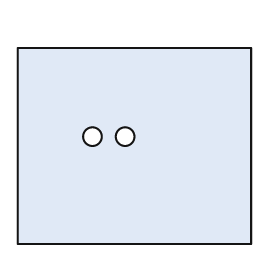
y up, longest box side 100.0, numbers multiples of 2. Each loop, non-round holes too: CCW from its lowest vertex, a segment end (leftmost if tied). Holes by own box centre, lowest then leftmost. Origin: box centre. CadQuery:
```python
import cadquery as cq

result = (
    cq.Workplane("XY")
    .moveTo(-50.0, -42.0)
    .lineTo(50.0, -42.0)
    .lineTo(50.0, 42.0)
    .lineTo(-50.0, 42.0)
    .close()
    .moveTo(-18.0, 4.0)
    .circle(4.0)
    .moveTo(-4.0, 4.0)
    .circle(4.0)
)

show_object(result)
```